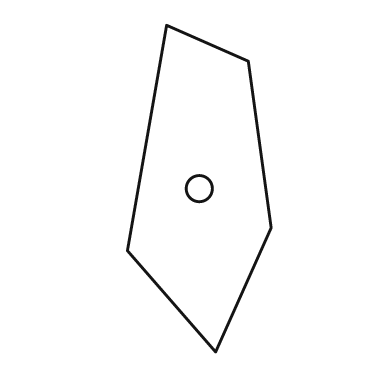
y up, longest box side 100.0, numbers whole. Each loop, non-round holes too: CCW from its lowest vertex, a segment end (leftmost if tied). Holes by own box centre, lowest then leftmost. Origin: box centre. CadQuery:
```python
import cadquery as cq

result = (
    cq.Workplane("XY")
    .moveTo(5.0, -50.0)
    .lineTo(22.0, -12.0)
    .lineTo(15.0, 39.0)
    .lineTo(-10.0, 50.0)
    .lineTo(-22.0, -19.0)
    .close()
    .moveTo(0.0, 0.0)
    .circle(4.0)
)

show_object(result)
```